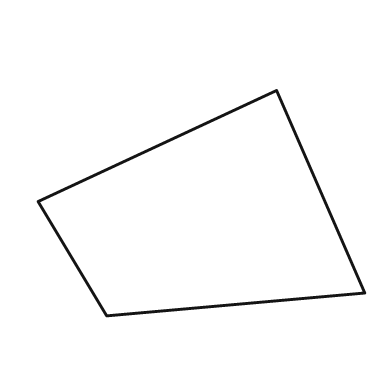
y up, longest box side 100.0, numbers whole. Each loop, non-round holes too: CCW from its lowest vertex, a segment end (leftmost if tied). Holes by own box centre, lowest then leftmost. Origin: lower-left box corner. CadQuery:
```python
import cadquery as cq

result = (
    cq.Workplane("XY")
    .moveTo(21.0, 0.0)
    .lineTo(100.0, 7.0)
    .lineTo(73.0, 69.0)
    .lineTo(0.0, 35.0)
    .close()
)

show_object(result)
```